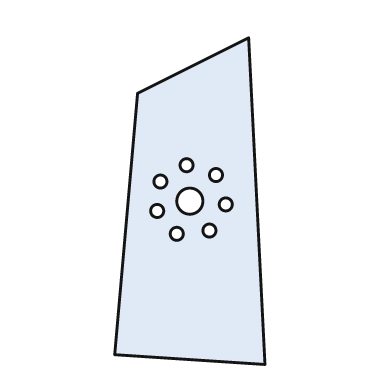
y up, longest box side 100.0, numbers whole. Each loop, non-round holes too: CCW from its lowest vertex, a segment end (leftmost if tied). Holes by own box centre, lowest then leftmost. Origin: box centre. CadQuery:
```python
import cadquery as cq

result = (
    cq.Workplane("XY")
    .moveTo(23.0, -50.0)
    .lineTo(18.0, 50.0)
    .lineTo(-16.0, 33.0)
    .lineTo(-23.0, -47.0)
    .close()
    .moveTo(-4.0, -10.0)
    .circle(2.0)
    .moveTo(6.0, -9.0)
    .circle(2.0)
    .moveTo(-10.0, -3.0)
    .circle(2.0)
    .moveTo(11.0, -1.0)
    .circle(2.0)
    .moveTo(0.0, 0.0)
    .circle(4.0)
    .moveTo(-9.0, 6.0)
    .circle(2.0)
    .moveTo(8.0, 8.0)
    .circle(2.0)
    .moveTo(-1.0, 11.0)
    .circle(2.0)
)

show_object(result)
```